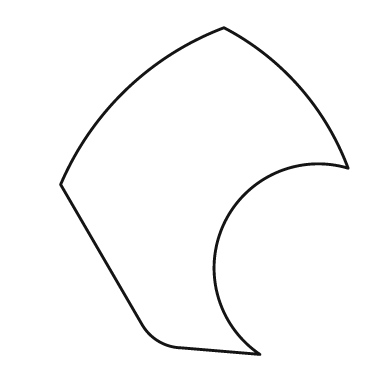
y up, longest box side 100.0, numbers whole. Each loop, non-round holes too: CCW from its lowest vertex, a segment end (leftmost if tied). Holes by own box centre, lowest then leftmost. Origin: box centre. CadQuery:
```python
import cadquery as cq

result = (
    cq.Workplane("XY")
    .moveTo(17.0, -50.0)
    .threePointArc((6.0, -10.0), (44.0, 7.0))
    .threePointArc((29.0, 32.0), (6.0, 50.0))
    .threePointArc((-24.0, 31.0), (-44.0, 2.0))
    .lineTo(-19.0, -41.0)
    .threePointArc((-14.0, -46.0), (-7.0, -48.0))
    .close()
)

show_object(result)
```